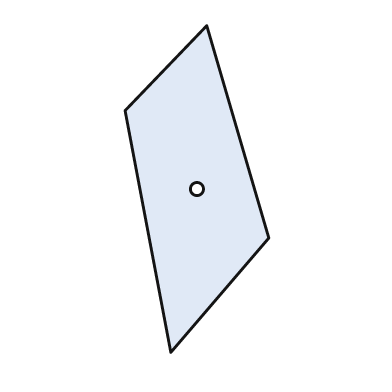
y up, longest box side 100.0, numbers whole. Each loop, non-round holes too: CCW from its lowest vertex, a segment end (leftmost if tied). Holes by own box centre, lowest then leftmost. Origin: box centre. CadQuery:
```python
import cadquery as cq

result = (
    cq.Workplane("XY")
    .moveTo(-8.0, -50.0)
    .lineTo(22.0, -15.0)
    .lineTo(3.0, 50.0)
    .lineTo(-22.0, 24.0)
    .close()
    .moveTo(0.0, 0.0)
    .circle(2.0)
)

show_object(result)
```